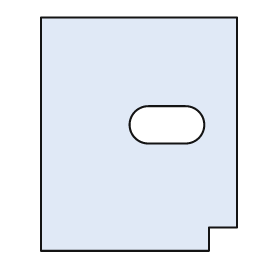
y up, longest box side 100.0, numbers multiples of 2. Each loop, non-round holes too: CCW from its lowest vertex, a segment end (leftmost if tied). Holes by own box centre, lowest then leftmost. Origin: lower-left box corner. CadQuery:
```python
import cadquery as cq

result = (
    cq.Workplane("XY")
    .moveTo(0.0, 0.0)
    .lineTo(72.0, 0.0)
    .lineTo(72.0, 10.0)
    .lineTo(84.0, 10.0)
    .lineTo(84.0, 100.0)
    .lineTo(0.0, 100.0)
    .close()
    .moveTo(46.0, 46.0)
    .lineTo(62.0, 46.0)
    .threePointArc((70.0, 54.0), (62.0, 62.0))
    .lineTo(46.0, 62.0)
    .threePointArc((38.0, 54.0), (46.0, 46.0))
    .close()
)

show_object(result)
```